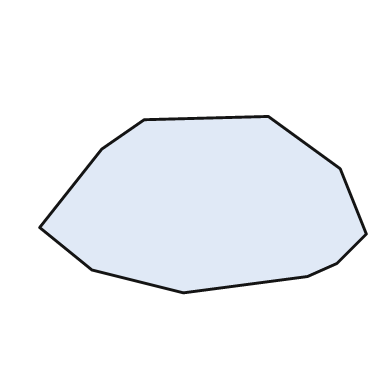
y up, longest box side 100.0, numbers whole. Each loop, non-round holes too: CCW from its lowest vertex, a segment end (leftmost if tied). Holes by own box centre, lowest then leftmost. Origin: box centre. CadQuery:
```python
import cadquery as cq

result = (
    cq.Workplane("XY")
    .moveTo(-6.0, -27.0)
    .lineTo(32.0, -22.0)
    .lineTo(41.0, -18.0)
    .lineTo(50.0, -9.0)
    .lineTo(42.0, 11.0)
    .lineTo(20.0, 27.0)
    .lineTo(-18.0, 26.0)
    .lineTo(-31.0, 17.0)
    .lineTo(-50.0, -7.0)
    .lineTo(-34.0, -20.0)
    .close()
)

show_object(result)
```